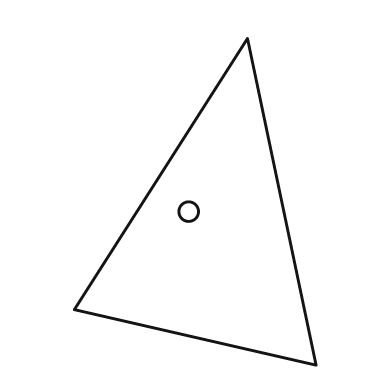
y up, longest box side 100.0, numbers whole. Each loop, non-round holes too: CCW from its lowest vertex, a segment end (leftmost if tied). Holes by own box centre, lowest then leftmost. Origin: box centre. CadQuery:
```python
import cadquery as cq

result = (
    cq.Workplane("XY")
    .moveTo(37.0, -50.0)
    .lineTo(16.0, 50.0)
    .lineTo(-37.0, -33.0)
    .close()
    .moveTo(-2.0, -3.0)
    .circle(3.0)
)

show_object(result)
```